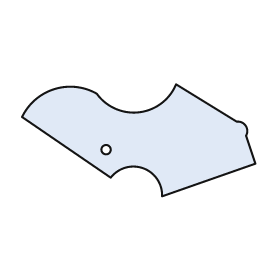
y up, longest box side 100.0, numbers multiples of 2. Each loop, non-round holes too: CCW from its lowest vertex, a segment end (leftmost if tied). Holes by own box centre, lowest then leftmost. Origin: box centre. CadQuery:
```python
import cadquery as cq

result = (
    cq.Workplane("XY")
    .moveTo(10.0, -24.0)
    .lineTo(50.0, -10.0)
    .lineTo(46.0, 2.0)
    .threePointArc((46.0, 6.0), (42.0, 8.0))
    .lineTo(16.0, 24.0)
    .threePointArc((0.0, 12.0), (-18.0, 20.0))
    .threePointArc((-36.0, 22.0), (-50.0, 10.0))
    .lineTo(-12.0, -16.0)
    .threePointArc((2.0, -12.0), (10.0, -24.0))
    .close()
    .moveTo(-14.0, -4.0)
    .circle(2.0)
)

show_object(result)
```